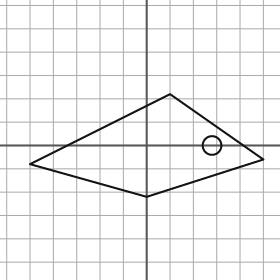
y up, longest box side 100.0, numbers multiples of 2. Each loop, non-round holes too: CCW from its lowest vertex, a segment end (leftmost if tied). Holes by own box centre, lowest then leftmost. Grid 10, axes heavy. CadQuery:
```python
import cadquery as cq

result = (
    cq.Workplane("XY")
    .moveTo(0.0, -22.0)
    .lineTo(50.0, -6.0)
    .lineTo(10.0, 22.0)
    .lineTo(-50.0, -8.0)
    .close()
    .moveTo(28.0, 0.0)
    .circle(4.0)
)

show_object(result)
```